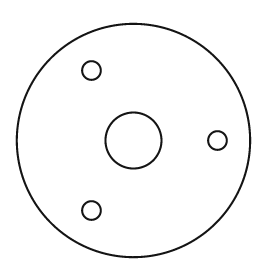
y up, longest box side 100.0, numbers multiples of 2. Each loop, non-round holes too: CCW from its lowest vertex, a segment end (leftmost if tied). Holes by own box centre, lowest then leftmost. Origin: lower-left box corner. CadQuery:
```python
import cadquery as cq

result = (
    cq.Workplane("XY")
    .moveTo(50.0, 50.0)
    .circle(50.0)
    .moveTo(32.0, 20.0)
    .circle(4.0)
    .moveTo(50.0, 50.0)
    .circle(12.0)
    .moveTo(86.0, 50.0)
    .circle(4.0)
    .moveTo(32.0, 80.0)
    .circle(4.0)
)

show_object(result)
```